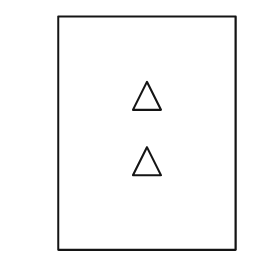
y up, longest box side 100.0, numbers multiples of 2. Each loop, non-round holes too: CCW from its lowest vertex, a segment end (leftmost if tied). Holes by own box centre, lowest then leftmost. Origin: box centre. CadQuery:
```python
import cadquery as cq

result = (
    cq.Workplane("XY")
    .moveTo(-38.0, -50.0)
    .lineTo(38.0, -50.0)
    .lineTo(38.0, 50.0)
    .lineTo(-38.0, 50.0)
    .close()
    .moveTo(-6.0, -18.0)
    .lineTo(6.0, -18.0)
    .lineTo(0.0, -6.0)
    .close()
    .moveTo(-6.0, 10.0)
    .lineTo(6.0, 10.0)
    .lineTo(0.0, 22.0)
    .close()
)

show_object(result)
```